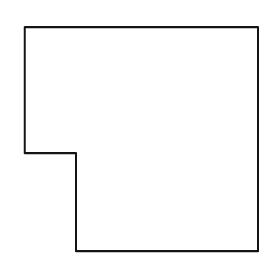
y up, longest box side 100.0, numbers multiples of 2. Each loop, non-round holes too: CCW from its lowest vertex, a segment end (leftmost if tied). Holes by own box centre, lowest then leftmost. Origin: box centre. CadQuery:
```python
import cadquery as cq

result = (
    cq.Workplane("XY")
    .moveTo(-28.0, -48.0)
    .lineTo(50.0, -48.0)
    .lineTo(50.0, 48.0)
    .lineTo(-50.0, 48.0)
    .lineTo(-50.0, -6.0)
    .lineTo(-28.0, -6.0)
    .close()
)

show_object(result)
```